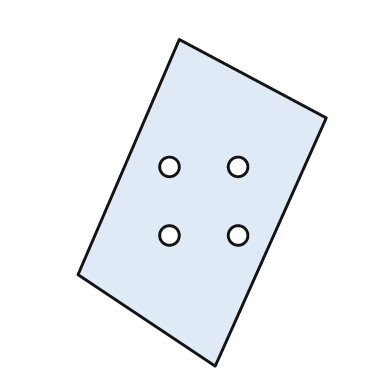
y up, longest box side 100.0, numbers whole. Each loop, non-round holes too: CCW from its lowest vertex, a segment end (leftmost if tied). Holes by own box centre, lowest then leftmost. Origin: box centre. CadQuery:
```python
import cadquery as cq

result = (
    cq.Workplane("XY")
    .moveTo(4.0, -50.0)
    .lineTo(38.0, 26.0)
    .lineTo(-7.0, 50.0)
    .lineTo(-38.0, -22.0)
    .close()
    .moveTo(-10.0, -10.0)
    .circle(3.0)
    .moveTo(11.0, -10.0)
    .circle(3.0)
    .moveTo(-10.0, 11.0)
    .circle(3.0)
    .moveTo(11.0, 11.0)
    .circle(3.0)
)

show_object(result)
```